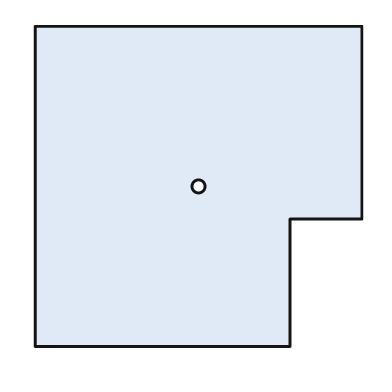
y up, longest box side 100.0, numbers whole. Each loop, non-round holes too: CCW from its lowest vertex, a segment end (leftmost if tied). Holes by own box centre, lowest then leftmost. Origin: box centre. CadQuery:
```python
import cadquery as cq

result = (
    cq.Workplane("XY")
    .moveTo(-50.0, -49.0)
    .lineTo(28.0, -49.0)
    .lineTo(28.0, -10.0)
    .lineTo(50.0, -10.0)
    .lineTo(50.0, 49.0)
    .lineTo(-50.0, 49.0)
    .close()
    .moveTo(0.0, 0.0)
    .circle(2.0)
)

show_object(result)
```